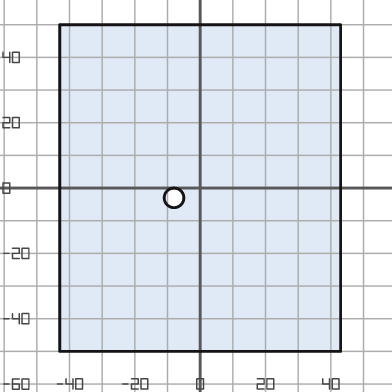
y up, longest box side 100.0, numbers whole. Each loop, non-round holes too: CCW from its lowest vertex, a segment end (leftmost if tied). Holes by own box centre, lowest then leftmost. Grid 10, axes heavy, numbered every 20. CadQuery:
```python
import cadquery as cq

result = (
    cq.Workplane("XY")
    .moveTo(-43.0, -50.0)
    .lineTo(43.0, -50.0)
    .lineTo(43.0, 50.0)
    .lineTo(-43.0, 50.0)
    .close()
    .moveTo(-8.0, -3.0)
    .circle(3.0)
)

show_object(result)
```